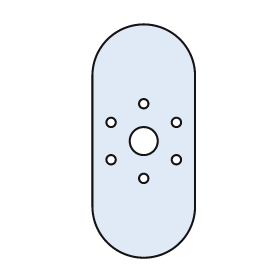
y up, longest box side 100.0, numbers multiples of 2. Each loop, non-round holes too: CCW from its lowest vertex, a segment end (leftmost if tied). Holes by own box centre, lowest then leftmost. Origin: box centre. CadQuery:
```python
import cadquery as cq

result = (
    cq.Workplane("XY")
    .moveTo(-22.0, -28.0)
    .threePointArc((0.0, -50.0), (22.0, -28.0))
    .lineTo(22.0, 28.0)
    .threePointArc((0.0, 50.0), (-22.0, 28.0))
    .close()
    .moveTo(0.0, -16.0)
    .circle(2.0)
    .moveTo(-14.0, -8.0)
    .circle(2.0)
    .moveTo(14.0, -8.0)
    .circle(2.0)
    .moveTo(0.0, 0.0)
    .circle(6.0)
    .moveTo(-14.0, 8.0)
    .circle(2.0)
    .moveTo(14.0, 8.0)
    .circle(2.0)
    .moveTo(0.0, 16.0)
    .circle(2.0)
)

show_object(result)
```